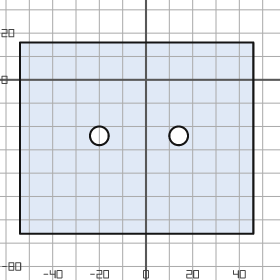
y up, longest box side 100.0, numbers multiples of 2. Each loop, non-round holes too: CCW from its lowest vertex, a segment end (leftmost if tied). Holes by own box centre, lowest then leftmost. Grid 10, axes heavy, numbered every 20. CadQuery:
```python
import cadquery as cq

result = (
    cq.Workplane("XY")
    .moveTo(-54.0, -66.0)
    .lineTo(46.0, -66.0)
    .lineTo(46.0, 16.0)
    .lineTo(-54.0, 16.0)
    .close()
    .moveTo(-20.0, -24.0)
    .circle(4.0)
    .moveTo(14.0, -24.0)
    .circle(4.0)
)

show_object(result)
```